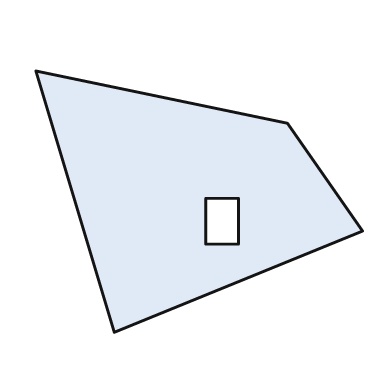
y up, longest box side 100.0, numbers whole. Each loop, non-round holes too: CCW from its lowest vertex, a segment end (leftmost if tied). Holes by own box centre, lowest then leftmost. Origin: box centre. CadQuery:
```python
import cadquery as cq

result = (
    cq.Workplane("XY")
    .moveTo(-26.0, -40.0)
    .lineTo(50.0, -9.0)
    .lineTo(27.0, 24.0)
    .lineTo(-50.0, 40.0)
    .close()
    .moveTo(2.0, -13.0)
    .lineTo(12.0, -13.0)
    .lineTo(12.0, 1.0)
    .lineTo(2.0, 1.0)
    .close()
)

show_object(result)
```